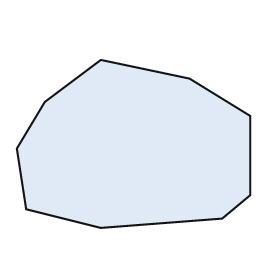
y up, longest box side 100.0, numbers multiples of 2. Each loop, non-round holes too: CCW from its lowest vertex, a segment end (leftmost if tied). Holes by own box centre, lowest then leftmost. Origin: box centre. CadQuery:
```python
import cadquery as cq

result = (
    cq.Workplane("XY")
    .moveTo(-14.0, -36.0)
    .lineTo(38.0, -32.0)
    .lineTo(50.0, -22.0)
    .lineTo(50.0, 12.0)
    .lineTo(24.0, 28.0)
    .lineTo(-14.0, 36.0)
    .lineTo(-38.0, 18.0)
    .lineTo(-50.0, -2.0)
    .lineTo(-46.0, -28.0)
    .close()
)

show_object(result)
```